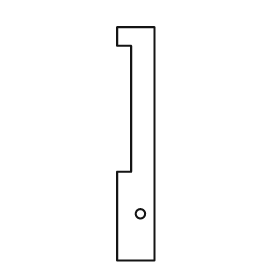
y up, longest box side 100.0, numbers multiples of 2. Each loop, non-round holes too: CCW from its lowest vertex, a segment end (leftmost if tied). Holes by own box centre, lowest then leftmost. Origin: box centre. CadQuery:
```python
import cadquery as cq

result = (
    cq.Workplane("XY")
    .moveTo(-8.0, -50.0)
    .lineTo(8.0, -50.0)
    .lineTo(8.0, 50.0)
    .lineTo(-8.0, 50.0)
    .lineTo(-8.0, 42.0)
    .lineTo(-2.0, 42.0)
    .lineTo(-2.0, -12.0)
    .lineTo(-8.0, -12.0)
    .close()
    .moveTo(2.0, -30.0)
    .circle(2.0)
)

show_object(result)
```